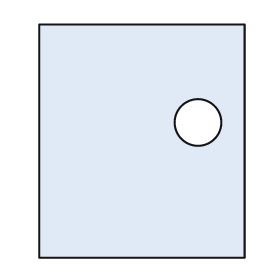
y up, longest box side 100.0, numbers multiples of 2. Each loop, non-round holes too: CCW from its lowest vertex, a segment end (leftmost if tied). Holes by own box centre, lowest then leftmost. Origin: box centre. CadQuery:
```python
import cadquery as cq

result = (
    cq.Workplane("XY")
    .moveTo(-44.0, -50.0)
    .lineTo(44.0, -50.0)
    .lineTo(44.0, 50.0)
    .lineTo(-44.0, 50.0)
    .close()
    .moveTo(24.0, 8.0)
    .circle(10.0)
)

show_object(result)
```